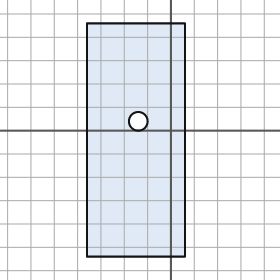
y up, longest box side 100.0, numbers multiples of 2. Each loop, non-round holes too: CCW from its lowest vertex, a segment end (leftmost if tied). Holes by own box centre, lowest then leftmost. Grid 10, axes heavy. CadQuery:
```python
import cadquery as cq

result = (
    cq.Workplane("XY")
    .moveTo(-36.0, -54.0)
    .lineTo(6.0, -54.0)
    .lineTo(6.0, 46.0)
    .lineTo(-36.0, 46.0)
    .close()
    .moveTo(-14.0, 4.0)
    .circle(4.0)
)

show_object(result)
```